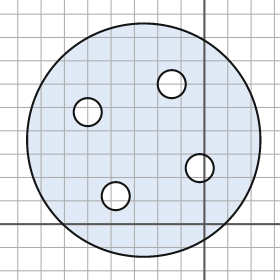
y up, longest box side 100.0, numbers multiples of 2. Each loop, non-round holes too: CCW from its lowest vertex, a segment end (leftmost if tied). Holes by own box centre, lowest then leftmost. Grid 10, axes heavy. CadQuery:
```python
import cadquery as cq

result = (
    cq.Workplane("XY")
    .moveTo(-26.0, 36.0)
    .circle(50.0)
    .moveTo(-38.0, 12.0)
    .circle(6.0)
    .moveTo(-2.0, 24.0)
    .circle(6.0)
    .moveTo(-50.0, 48.0)
    .circle(6.0)
    .moveTo(-14.0, 60.0)
    .circle(6.0)
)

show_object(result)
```